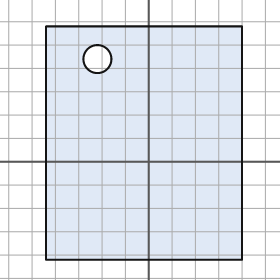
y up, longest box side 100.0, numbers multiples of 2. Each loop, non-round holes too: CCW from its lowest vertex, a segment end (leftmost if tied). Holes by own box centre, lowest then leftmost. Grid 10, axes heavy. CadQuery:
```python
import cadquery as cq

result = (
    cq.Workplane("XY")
    .moveTo(-44.0, -42.0)
    .lineTo(40.0, -42.0)
    .lineTo(40.0, 58.0)
    .lineTo(-44.0, 58.0)
    .close()
    .moveTo(-22.0, 44.0)
    .circle(6.0)
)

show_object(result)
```